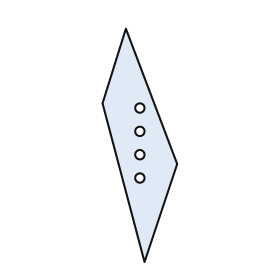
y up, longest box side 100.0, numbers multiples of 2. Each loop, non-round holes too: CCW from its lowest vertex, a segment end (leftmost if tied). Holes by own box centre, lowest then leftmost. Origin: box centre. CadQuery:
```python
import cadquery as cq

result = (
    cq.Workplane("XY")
    .moveTo(2.0, -50.0)
    .lineTo(16.0, -8.0)
    .lineTo(-6.0, 50.0)
    .lineTo(-16.0, 18.0)
    .close()
    .moveTo(0.0, -14.0)
    .circle(2.0)
    .moveTo(0.0, -4.0)
    .circle(2.0)
    .moveTo(0.0, 6.0)
    .circle(2.0)
    .moveTo(0.0, 16.0)
    .circle(2.0)
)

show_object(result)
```